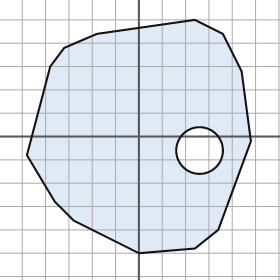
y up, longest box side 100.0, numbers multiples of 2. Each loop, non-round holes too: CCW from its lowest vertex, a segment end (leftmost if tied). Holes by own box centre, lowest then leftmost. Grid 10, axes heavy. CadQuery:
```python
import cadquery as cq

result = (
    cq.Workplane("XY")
    .moveTo(0.0, -50.0)
    .lineTo(24.0, -48.0)
    .lineTo(34.0, -40.0)
    .lineTo(48.0, -2.0)
    .lineTo(44.0, 28.0)
    .lineTo(36.0, 44.0)
    .lineTo(24.0, 50.0)
    .lineTo(-18.0, 44.0)
    .lineTo(-32.0, 38.0)
    .lineTo(-38.0, 30.0)
    .lineTo(-48.0, -8.0)
    .lineTo(-36.0, -28.0)
    .lineTo(-28.0, -36.0)
    .close()
    .moveTo(26.0, -6.0)
    .circle(10.0)
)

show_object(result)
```